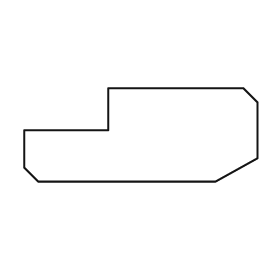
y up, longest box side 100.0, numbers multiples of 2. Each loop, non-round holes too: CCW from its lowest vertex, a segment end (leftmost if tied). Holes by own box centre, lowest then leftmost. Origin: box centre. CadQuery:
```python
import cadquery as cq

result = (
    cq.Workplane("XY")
    .moveTo(-44.0, -20.0)
    .lineTo(32.0, -20.0)
    .lineTo(50.0, -10.0)
    .lineTo(50.0, 14.0)
    .lineTo(44.0, 20.0)
    .lineTo(-14.0, 20.0)
    .lineTo(-14.0, 2.0)
    .lineTo(-50.0, 2.0)
    .lineTo(-50.0, -14.0)
    .close()
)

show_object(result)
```